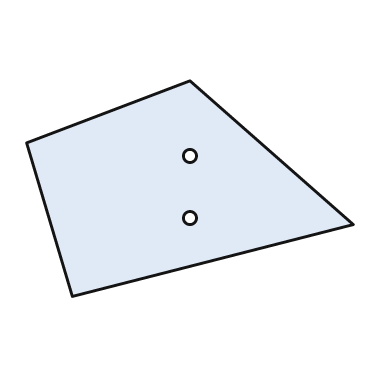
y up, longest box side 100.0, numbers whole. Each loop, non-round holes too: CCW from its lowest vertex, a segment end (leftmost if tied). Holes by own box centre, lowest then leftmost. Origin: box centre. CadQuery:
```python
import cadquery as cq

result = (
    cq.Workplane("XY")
    .moveTo(-36.0, -33.0)
    .lineTo(50.0, -11.0)
    .lineTo(0.0, 33.0)
    .lineTo(-50.0, 14.0)
    .close()
    .moveTo(0.0, -9.0)
    .circle(2.0)
    .moveTo(0.0, 10.0)
    .circle(2.0)
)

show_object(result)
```